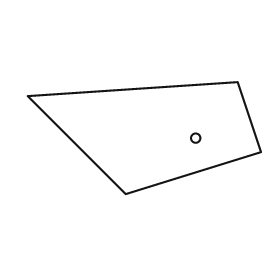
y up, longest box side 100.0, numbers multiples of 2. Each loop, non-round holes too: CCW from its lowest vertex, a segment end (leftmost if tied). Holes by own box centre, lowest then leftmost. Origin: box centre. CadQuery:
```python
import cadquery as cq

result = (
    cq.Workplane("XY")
    .moveTo(-8.0, -24.0)
    .lineTo(50.0, -6.0)
    .lineTo(40.0, 24.0)
    .lineTo(-50.0, 18.0)
    .close()
    .moveTo(22.0, 0.0)
    .circle(2.0)
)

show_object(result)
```